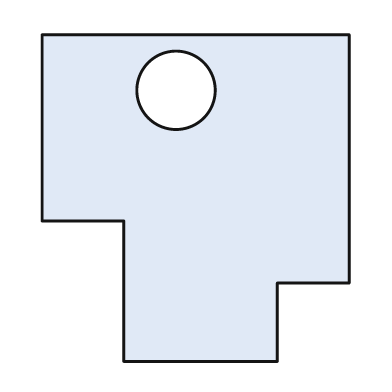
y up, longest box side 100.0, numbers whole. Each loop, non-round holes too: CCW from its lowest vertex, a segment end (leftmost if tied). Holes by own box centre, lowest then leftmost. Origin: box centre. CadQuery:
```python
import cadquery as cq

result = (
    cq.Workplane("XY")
    .moveTo(-22.0, -50.0)
    .lineTo(25.0, -50.0)
    .lineTo(25.0, -26.0)
    .lineTo(47.0, -26.0)
    .lineTo(47.0, 50.0)
    .lineTo(-47.0, 50.0)
    .lineTo(-47.0, -7.0)
    .lineTo(-22.0, -7.0)
    .close()
    .moveTo(-6.0, 33.0)
    .circle(12.0)
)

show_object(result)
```